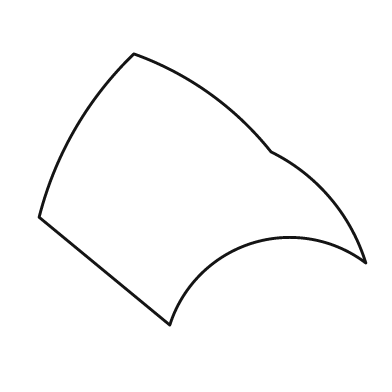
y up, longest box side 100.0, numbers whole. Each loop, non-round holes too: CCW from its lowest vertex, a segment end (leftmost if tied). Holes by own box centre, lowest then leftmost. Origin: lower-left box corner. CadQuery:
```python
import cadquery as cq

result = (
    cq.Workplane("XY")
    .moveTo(40.0, 0.0)
    .threePointArc((65.0, 25.0), (100.0, 19.0))
    .threePointArc((89.0, 39.0), (71.0, 53.0))
    .threePointArc((52.0, 71.0), (29.0, 83.0))
    .threePointArc((11.0, 60.0), (0.0, 33.0))
    .close()
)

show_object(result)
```